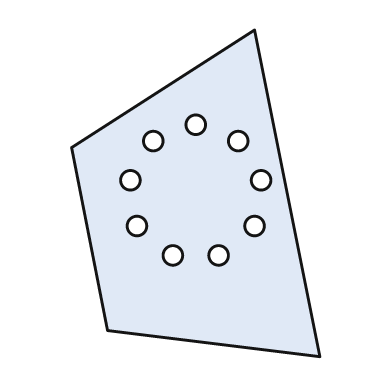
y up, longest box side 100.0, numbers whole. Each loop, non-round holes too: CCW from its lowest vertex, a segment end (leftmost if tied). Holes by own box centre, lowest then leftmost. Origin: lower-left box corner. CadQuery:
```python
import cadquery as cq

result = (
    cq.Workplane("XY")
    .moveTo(76.0, 0.0)
    .lineTo(56.0, 100.0)
    .lineTo(0.0, 64.0)
    .lineTo(11.0, 8.0)
    .close()
    .moveTo(31.0, 31.0)
    .circle(3.0)
    .moveTo(45.0, 31.0)
    .circle(3.0)
    .moveTo(20.0, 40.0)
    .circle(3.0)
    .moveTo(56.0, 40.0)
    .circle(3.0)
    .moveTo(18.0, 54.0)
    .circle(3.0)
    .moveTo(58.0, 54.0)
    .circle(3.0)
    .moveTo(25.0, 66.0)
    .circle(3.0)
    .moveTo(51.0, 66.0)
    .circle(3.0)
    .moveTo(38.0, 71.0)
    .circle(3.0)
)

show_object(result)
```